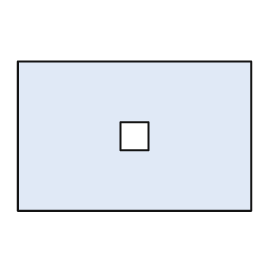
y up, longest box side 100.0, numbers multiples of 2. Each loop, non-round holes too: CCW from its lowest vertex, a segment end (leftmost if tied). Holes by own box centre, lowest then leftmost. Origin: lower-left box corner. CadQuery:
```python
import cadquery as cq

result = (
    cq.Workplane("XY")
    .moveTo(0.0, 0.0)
    .lineTo(100.0, 0.0)
    .lineTo(100.0, 64.0)
    .lineTo(0.0, 64.0)
    .close()
    .moveTo(44.0, 26.0)
    .lineTo(56.0, 26.0)
    .lineTo(56.0, 38.0)
    .lineTo(44.0, 38.0)
    .close()
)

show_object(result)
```